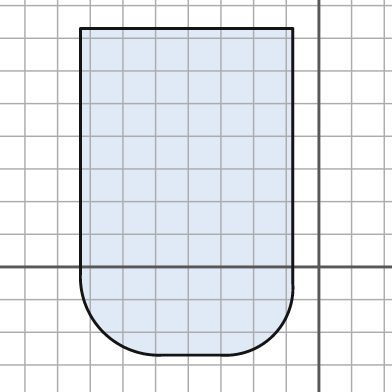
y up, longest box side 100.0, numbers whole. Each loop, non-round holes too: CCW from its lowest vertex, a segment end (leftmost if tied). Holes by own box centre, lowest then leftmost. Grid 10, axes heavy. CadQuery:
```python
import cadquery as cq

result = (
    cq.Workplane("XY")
    .moveTo(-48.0, -27.0)
    .lineTo(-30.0, -27.0)
    .threePointArc((-14.0, -21.0), (-8.0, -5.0))
    .lineTo(-8.0, 73.0)
    .lineTo(-73.0, 73.0)
    .lineTo(-73.0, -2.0)
    .threePointArc((-66.0, -20.0), (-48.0, -27.0))
    .close()
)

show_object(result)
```